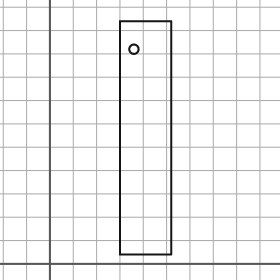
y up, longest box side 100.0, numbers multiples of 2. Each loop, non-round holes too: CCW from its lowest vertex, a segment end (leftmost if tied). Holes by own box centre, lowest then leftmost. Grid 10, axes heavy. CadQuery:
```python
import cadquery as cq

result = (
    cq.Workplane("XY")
    .moveTo(30.0, 4.0)
    .lineTo(52.0, 4.0)
    .lineTo(52.0, 104.0)
    .lineTo(30.0, 104.0)
    .close()
    .moveTo(36.0, 92.0)
    .circle(2.0)
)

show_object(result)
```